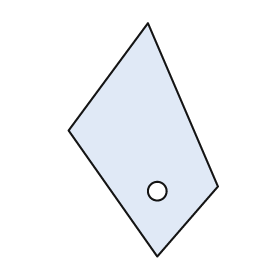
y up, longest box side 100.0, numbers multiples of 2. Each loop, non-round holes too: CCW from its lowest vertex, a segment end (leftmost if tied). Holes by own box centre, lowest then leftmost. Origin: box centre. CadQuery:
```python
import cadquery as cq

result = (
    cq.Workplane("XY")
    .moveTo(6.0, -50.0)
    .lineTo(32.0, -20.0)
    .lineTo(2.0, 50.0)
    .lineTo(-32.0, 4.0)
    .close()
    .moveTo(6.0, -22.0)
    .circle(4.0)
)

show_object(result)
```